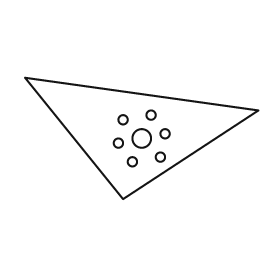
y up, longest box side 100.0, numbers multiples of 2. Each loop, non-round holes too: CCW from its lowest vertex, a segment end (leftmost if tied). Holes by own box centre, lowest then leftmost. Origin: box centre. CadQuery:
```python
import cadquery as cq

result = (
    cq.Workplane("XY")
    .moveTo(-8.0, -26.0)
    .lineTo(50.0, 12.0)
    .lineTo(-50.0, 26.0)
    .close()
    .moveTo(-4.0, -10.0)
    .circle(2.0)
    .moveTo(8.0, -8.0)
    .circle(2.0)
    .moveTo(-10.0, -2.0)
    .circle(2.0)
    .moveTo(0.0, 0.0)
    .circle(4.0)
    .moveTo(10.0, 2.0)
    .circle(2.0)
    .moveTo(-8.0, 8.0)
    .circle(2.0)
    .moveTo(4.0, 10.0)
    .circle(2.0)
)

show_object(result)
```